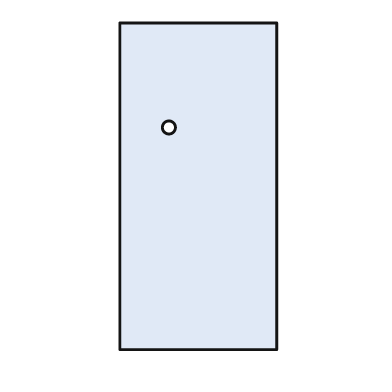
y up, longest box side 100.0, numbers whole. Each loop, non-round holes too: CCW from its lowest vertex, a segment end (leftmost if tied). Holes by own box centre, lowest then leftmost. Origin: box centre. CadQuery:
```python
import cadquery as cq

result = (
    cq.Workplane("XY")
    .moveTo(-24.0, -50.0)
    .lineTo(24.0, -50.0)
    .lineTo(24.0, 50.0)
    .lineTo(-24.0, 50.0)
    .close()
    .moveTo(-9.0, 18.0)
    .circle(2.0)
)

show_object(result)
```